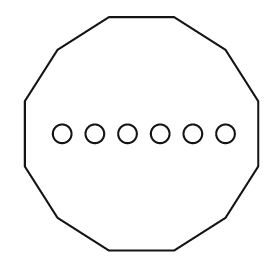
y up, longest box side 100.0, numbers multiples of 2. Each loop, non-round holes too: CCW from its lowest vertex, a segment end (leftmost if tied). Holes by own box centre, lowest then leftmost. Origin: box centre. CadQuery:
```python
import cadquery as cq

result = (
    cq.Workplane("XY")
    .moveTo(-14.0, -50.0)
    .lineTo(14.0, -50.0)
    .lineTo(36.0, -36.0)
    .lineTo(50.0, -14.0)
    .lineTo(50.0, 14.0)
    .lineTo(36.0, 36.0)
    .lineTo(14.0, 50.0)
    .lineTo(-14.0, 50.0)
    .lineTo(-36.0, 36.0)
    .lineTo(-50.0, 14.0)
    .lineTo(-50.0, -14.0)
    .lineTo(-36.0, -36.0)
    .close()
    .moveTo(-34.0, 0.0)
    .circle(4.0)
    .moveTo(-20.0, 0.0)
    .circle(4.0)
    .moveTo(-6.0, 0.0)
    .circle(4.0)
    .moveTo(8.0, 0.0)
    .circle(4.0)
    .moveTo(22.0, 0.0)
    .circle(4.0)
    .moveTo(36.0, 0.0)
    .circle(4.0)
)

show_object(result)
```